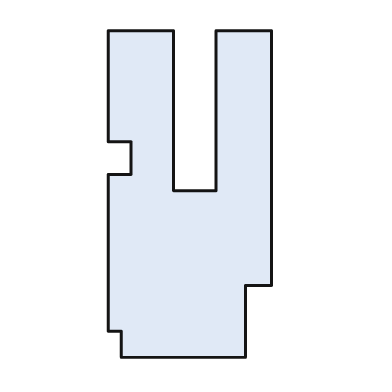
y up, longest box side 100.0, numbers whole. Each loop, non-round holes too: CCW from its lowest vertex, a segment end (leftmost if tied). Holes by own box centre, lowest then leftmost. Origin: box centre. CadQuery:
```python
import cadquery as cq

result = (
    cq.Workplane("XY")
    .moveTo(-21.0, -50.0)
    .lineTo(17.0, -50.0)
    .lineTo(17.0, -28.0)
    .lineTo(25.0, -28.0)
    .lineTo(25.0, 50.0)
    .lineTo(8.0, 50.0)
    .lineTo(8.0, 1.0)
    .lineTo(-5.0, 1.0)
    .lineTo(-5.0, 50.0)
    .lineTo(-25.0, 50.0)
    .lineTo(-25.0, 16.0)
    .lineTo(-18.0, 16.0)
    .lineTo(-18.0, 6.0)
    .lineTo(-25.0, 6.0)
    .lineTo(-25.0, -42.0)
    .lineTo(-21.0, -42.0)
    .close()
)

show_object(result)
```